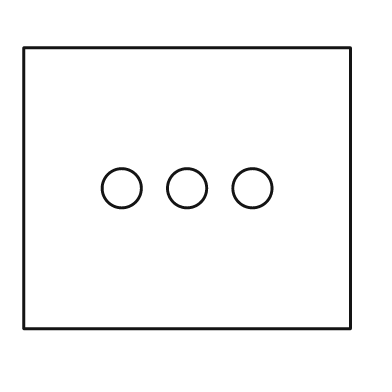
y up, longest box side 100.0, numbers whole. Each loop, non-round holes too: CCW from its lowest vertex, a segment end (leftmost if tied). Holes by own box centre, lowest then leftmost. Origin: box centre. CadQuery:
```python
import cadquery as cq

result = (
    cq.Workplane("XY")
    .moveTo(-50.0, -43.0)
    .lineTo(50.0, -43.0)
    .lineTo(50.0, 43.0)
    .lineTo(-50.0, 43.0)
    .close()
    .moveTo(-20.0, 0.0)
    .circle(6.0)
    .moveTo(0.0, 0.0)
    .circle(6.0)
    .moveTo(20.0, 0.0)
    .circle(6.0)
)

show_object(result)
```